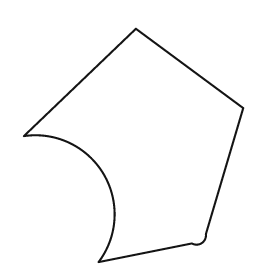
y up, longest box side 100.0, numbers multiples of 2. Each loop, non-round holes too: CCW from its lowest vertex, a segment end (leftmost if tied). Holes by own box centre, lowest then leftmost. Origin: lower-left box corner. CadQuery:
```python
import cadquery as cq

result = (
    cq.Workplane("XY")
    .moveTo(32.0, 0.0)
    .lineTo(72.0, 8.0)
    .threePointArc((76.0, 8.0), (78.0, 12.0))
    .lineTo(94.0, 66.0)
    .lineTo(48.0, 100.0)
    .lineTo(0.0, 54.0)
    .threePointArc((34.0, 38.0), (32.0, 0.0))
    .close()
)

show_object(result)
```